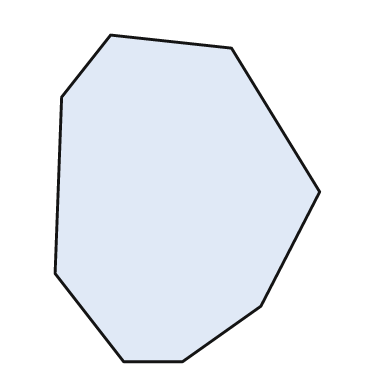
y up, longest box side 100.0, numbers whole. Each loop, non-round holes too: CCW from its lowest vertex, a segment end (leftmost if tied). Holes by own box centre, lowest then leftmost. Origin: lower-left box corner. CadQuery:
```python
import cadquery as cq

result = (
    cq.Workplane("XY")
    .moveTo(21.0, 0.0)
    .lineTo(39.0, 0.0)
    .lineTo(63.0, 17.0)
    .lineTo(81.0, 52.0)
    .lineTo(54.0, 96.0)
    .lineTo(17.0, 100.0)
    .lineTo(2.0, 81.0)
    .lineTo(0.0, 27.0)
    .close()
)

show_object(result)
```